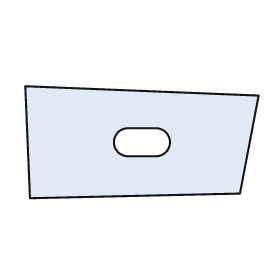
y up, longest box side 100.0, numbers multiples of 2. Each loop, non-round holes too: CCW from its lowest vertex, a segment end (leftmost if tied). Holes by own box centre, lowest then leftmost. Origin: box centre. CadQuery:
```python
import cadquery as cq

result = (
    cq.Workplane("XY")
    .moveTo(-48.0, -24.0)
    .lineTo(42.0, -22.0)
    .lineTo(50.0, 20.0)
    .lineTo(-50.0, 24.0)
    .close()
    .moveTo(-6.0, -6.0)
    .lineTo(6.0, -6.0)
    .threePointArc((12.0, 0.0), (6.0, 6.0))
    .lineTo(-6.0, 6.0)
    .threePointArc((-12.0, 0.0), (-6.0, -6.0))
    .close()
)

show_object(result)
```